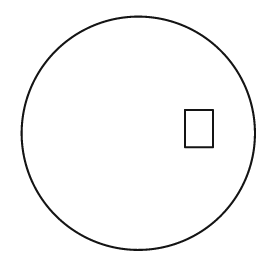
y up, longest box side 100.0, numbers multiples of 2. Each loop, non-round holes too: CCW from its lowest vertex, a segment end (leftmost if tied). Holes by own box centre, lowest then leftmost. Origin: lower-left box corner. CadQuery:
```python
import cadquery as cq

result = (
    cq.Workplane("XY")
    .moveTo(50.0, 50.0)
    .circle(50.0)
    .moveTo(70.0, 44.0)
    .lineTo(82.0, 44.0)
    .lineTo(82.0, 60.0)
    .lineTo(70.0, 60.0)
    .close()
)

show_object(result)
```